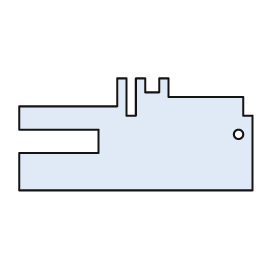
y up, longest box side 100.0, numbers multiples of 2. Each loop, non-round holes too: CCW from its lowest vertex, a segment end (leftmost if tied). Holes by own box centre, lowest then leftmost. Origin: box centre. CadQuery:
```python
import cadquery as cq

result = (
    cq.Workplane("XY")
    .moveTo(-50.0, -24.0)
    .lineTo(50.0, -24.0)
    .lineTo(50.0, 8.0)
    .lineTo(46.0, 8.0)
    .lineTo(46.0, 16.0)
    .lineTo(14.0, 16.0)
    .lineTo(14.0, 24.0)
    .lineTo(10.0, 24.0)
    .lineTo(10.0, 18.0)
    .lineTo(4.0, 18.0)
    .lineTo(4.0, 24.0)
    .lineTo(0.0, 24.0)
    .lineTo(0.0, 8.0)
    .lineTo(-4.0, 8.0)
    .lineTo(-4.0, 24.0)
    .lineTo(-8.0, 24.0)
    .lineTo(-8.0, 12.0)
    .lineTo(-50.0, 12.0)
    .lineTo(-50.0, 2.0)
    .lineTo(-16.0, 2.0)
    .lineTo(-16.0, -8.0)
    .lineTo(-50.0, -8.0)
    .close()
    .moveTo(44.0, 0.0)
    .circle(2.0)
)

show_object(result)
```